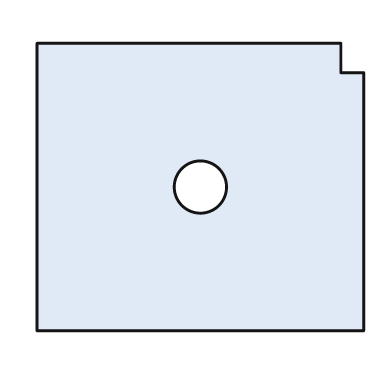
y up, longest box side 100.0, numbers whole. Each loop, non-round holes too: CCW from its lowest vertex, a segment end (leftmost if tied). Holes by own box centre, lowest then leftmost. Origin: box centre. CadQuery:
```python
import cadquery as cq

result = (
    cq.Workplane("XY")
    .moveTo(-50.0, -44.0)
    .lineTo(50.0, -44.0)
    .lineTo(50.0, 35.0)
    .lineTo(43.0, 35.0)
    .lineTo(43.0, 44.0)
    .lineTo(-50.0, 44.0)
    .close()
    .moveTo(0.0, 0.0)
    .circle(8.0)
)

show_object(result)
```